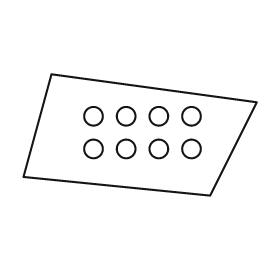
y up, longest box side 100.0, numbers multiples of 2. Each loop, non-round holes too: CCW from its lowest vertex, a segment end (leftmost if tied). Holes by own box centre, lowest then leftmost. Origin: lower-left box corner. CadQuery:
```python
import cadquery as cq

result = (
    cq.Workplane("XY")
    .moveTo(80.0, 0.0)
    .lineTo(100.0, 40.0)
    .lineTo(12.0, 52.0)
    .lineTo(0.0, 8.0)
    .close()
    .moveTo(30.0, 20.0)
    .circle(4.0)
    .moveTo(44.0, 20.0)
    .circle(4.0)
    .moveTo(58.0, 20.0)
    .circle(4.0)
    .moveTo(72.0, 20.0)
    .circle(4.0)
    .moveTo(30.0, 34.0)
    .circle(4.0)
    .moveTo(44.0, 34.0)
    .circle(4.0)
    .moveTo(58.0, 34.0)
    .circle(4.0)
    .moveTo(72.0, 34.0)
    .circle(4.0)
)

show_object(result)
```